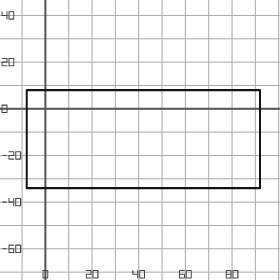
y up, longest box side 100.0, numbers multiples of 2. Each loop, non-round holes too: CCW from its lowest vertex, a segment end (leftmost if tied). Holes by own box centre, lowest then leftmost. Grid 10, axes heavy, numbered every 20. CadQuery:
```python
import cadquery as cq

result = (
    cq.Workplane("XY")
    .moveTo(-8.0, -34.0)
    .lineTo(92.0, -34.0)
    .lineTo(92.0, 8.0)
    .lineTo(-8.0, 8.0)
    .close()
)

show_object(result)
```